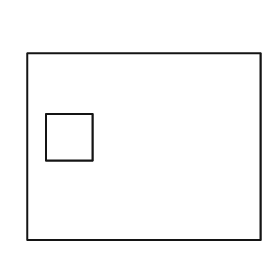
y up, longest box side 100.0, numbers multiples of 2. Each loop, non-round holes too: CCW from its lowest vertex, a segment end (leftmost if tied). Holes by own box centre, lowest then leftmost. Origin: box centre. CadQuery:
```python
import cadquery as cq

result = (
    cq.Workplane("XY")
    .moveTo(-50.0, -40.0)
    .lineTo(50.0, -40.0)
    .lineTo(50.0, 40.0)
    .lineTo(-50.0, 40.0)
    .close()
    .moveTo(-42.0, -6.0)
    .lineTo(-22.0, -6.0)
    .lineTo(-22.0, 14.0)
    .lineTo(-42.0, 14.0)
    .close()
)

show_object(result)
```